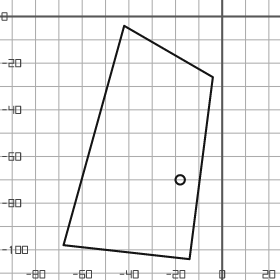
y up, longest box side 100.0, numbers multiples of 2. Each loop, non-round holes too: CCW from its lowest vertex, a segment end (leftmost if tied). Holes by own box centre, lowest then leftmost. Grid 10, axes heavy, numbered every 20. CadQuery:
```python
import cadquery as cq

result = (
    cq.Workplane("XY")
    .moveTo(-14.0, -104.0)
    .lineTo(-4.0, -26.0)
    .lineTo(-42.0, -4.0)
    .lineTo(-68.0, -98.0)
    .close()
    .moveTo(-18.0, -70.0)
    .circle(2.0)
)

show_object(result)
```